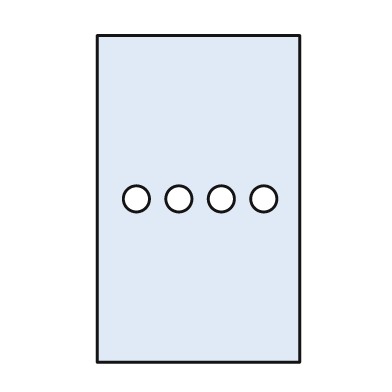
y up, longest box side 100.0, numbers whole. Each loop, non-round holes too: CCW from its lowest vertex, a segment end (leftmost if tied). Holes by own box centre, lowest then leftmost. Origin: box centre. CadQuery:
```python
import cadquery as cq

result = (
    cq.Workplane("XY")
    .moveTo(-31.0, -50.0)
    .lineTo(31.0, -50.0)
    .lineTo(31.0, 50.0)
    .lineTo(-31.0, 50.0)
    .close()
    .moveTo(-19.0, 0.0)
    .circle(4.0)
    .moveTo(-6.0, 0.0)
    .circle(4.0)
    .moveTo(7.0, 0.0)
    .circle(4.0)
    .moveTo(20.0, 0.0)
    .circle(4.0)
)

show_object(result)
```